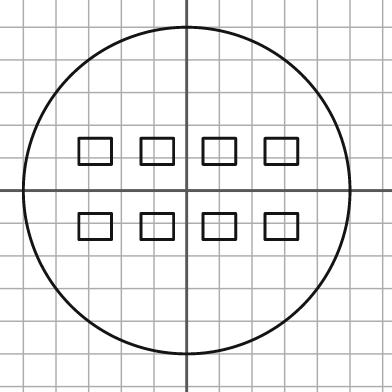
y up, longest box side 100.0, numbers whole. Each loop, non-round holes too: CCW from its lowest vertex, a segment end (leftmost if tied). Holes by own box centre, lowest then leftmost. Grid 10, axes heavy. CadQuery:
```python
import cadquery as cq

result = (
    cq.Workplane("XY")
    .moveTo(0.0, 0.0)
    .circle(50.0)
    .moveTo(-33.0, -15.0)
    .lineTo(-23.0, -15.0)
    .lineTo(-23.0, -7.0)
    .lineTo(-33.0, -7.0)
    .close()
    .moveTo(-14.0, -15.0)
    .lineTo(-4.0, -15.0)
    .lineTo(-4.0, -7.0)
    .lineTo(-14.0, -7.0)
    .close()
    .moveTo(5.0, -15.0)
    .lineTo(15.0, -15.0)
    .lineTo(15.0, -7.0)
    .lineTo(5.0, -7.0)
    .close()
    .moveTo(24.0, -15.0)
    .lineTo(34.0, -15.0)
    .lineTo(34.0, -7.0)
    .lineTo(24.0, -7.0)
    .close()
    .moveTo(-33.0, 8.0)
    .lineTo(-23.0, 8.0)
    .lineTo(-23.0, 16.0)
    .lineTo(-33.0, 16.0)
    .close()
    .moveTo(-14.0, 8.0)
    .lineTo(-4.0, 8.0)
    .lineTo(-4.0, 16.0)
    .lineTo(-14.0, 16.0)
    .close()
    .moveTo(5.0, 8.0)
    .lineTo(15.0, 8.0)
    .lineTo(15.0, 16.0)
    .lineTo(5.0, 16.0)
    .close()
    .moveTo(24.0, 8.0)
    .lineTo(34.0, 8.0)
    .lineTo(34.0, 16.0)
    .lineTo(24.0, 16.0)
    .close()
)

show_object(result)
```